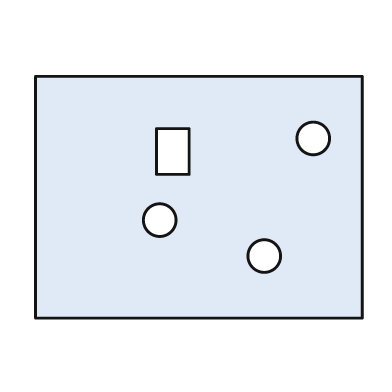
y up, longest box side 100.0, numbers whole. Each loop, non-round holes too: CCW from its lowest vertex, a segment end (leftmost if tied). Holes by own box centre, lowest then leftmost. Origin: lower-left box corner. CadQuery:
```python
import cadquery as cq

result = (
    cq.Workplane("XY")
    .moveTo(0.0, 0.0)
    .lineTo(100.0, 0.0)
    .lineTo(100.0, 74.0)
    .lineTo(0.0, 74.0)
    .close()
    .moveTo(70.0, 19.0)
    .circle(5.0)
    .moveTo(38.0, 30.0)
    .circle(5.0)
    .moveTo(37.0, 44.0)
    .lineTo(47.0, 44.0)
    .lineTo(47.0, 58.0)
    .lineTo(37.0, 58.0)
    .close()
    .moveTo(85.0, 55.0)
    .circle(5.0)
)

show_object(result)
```